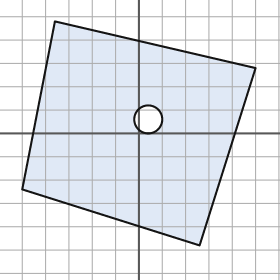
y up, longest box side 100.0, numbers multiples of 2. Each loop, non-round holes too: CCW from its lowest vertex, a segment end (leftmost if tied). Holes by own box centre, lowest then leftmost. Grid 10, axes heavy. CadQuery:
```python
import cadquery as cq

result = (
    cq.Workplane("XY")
    .moveTo(26.0, -48.0)
    .lineTo(50.0, 28.0)
    .lineTo(-36.0, 48.0)
    .lineTo(-50.0, -24.0)
    .close()
    .moveTo(4.0, 6.0)
    .circle(6.0)
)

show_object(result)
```